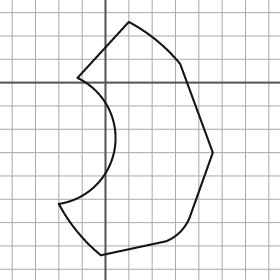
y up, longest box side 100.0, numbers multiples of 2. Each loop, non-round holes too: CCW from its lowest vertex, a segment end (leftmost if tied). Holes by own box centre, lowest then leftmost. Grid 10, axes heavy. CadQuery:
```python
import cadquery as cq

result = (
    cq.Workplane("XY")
    .moveTo(-2.0, -74.0)
    .lineTo(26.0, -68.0)
    .threePointArc((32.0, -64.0), (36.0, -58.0))
    .lineTo(46.0, -30.0)
    .lineTo(32.0, 8.0)
    .threePointArc((22.0, 18.0), (10.0, 26.0))
    .lineTo(-12.0, 2.0)
    .threePointArc((4.0, -28.0), (-20.0, -52.0))
    .threePointArc((-12.0, -64.0), (-2.0, -74.0))
    .close()
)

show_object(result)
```